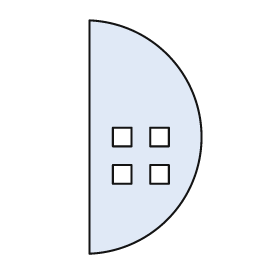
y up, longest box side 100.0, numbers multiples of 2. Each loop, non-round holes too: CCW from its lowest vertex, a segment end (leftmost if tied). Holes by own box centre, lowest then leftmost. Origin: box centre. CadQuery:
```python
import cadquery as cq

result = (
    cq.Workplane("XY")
    .moveTo(-24.0, -50.0)
    .threePointArc((24.0, 0.0), (-24.0, 50.0))
    .close()
    .moveTo(-14.0, -20.0)
    .lineTo(-6.0, -20.0)
    .lineTo(-6.0, -12.0)
    .lineTo(-14.0, -12.0)
    .close()
    .moveTo(2.0, -20.0)
    .lineTo(10.0, -20.0)
    .lineTo(10.0, -12.0)
    .lineTo(2.0, -12.0)
    .close()
    .moveTo(-14.0, -4.0)
    .lineTo(-6.0, -4.0)
    .lineTo(-6.0, 4.0)
    .lineTo(-14.0, 4.0)
    .close()
    .moveTo(2.0, -4.0)
    .lineTo(10.0, -4.0)
    .lineTo(10.0, 4.0)
    .lineTo(2.0, 4.0)
    .close()
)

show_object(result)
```